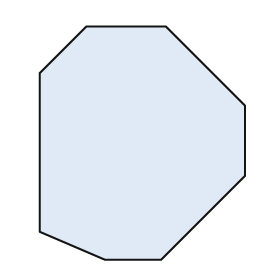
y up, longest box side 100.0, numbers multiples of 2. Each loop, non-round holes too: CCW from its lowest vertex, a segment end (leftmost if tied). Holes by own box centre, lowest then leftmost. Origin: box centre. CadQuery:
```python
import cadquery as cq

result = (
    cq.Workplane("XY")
    .moveTo(-16.0, -50.0)
    .lineTo(8.0, -50.0)
    .lineTo(44.0, -14.0)
    .lineTo(44.0, 16.0)
    .lineTo(10.0, 50.0)
    .lineTo(-24.0, 50.0)
    .lineTo(-44.0, 30.0)
    .lineTo(-44.0, -38.0)
    .close()
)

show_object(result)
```